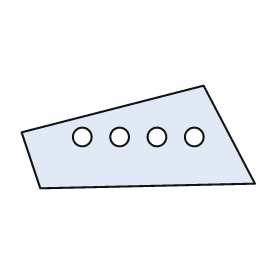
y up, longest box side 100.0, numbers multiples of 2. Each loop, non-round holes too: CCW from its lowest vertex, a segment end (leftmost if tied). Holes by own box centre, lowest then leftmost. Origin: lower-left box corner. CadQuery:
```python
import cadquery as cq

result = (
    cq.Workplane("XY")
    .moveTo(8.0, 0.0)
    .lineTo(100.0, 2.0)
    .lineTo(78.0, 44.0)
    .lineTo(0.0, 24.0)
    .close()
    .moveTo(26.0, 22.0)
    .circle(4.0)
    .moveTo(42.0, 22.0)
    .circle(4.0)
    .moveTo(58.0, 22.0)
    .circle(4.0)
    .moveTo(74.0, 22.0)
    .circle(4.0)
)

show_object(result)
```